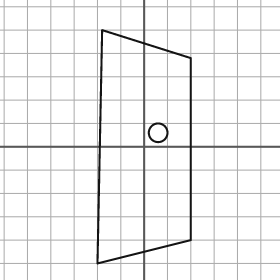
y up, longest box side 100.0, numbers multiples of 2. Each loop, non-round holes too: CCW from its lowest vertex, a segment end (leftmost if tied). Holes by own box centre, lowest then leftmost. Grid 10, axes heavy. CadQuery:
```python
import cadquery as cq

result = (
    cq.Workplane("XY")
    .moveTo(-20.0, -50.0)
    .lineTo(20.0, -40.0)
    .lineTo(20.0, 38.0)
    .lineTo(-18.0, 50.0)
    .close()
    .moveTo(6.0, 6.0)
    .circle(4.0)
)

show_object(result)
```